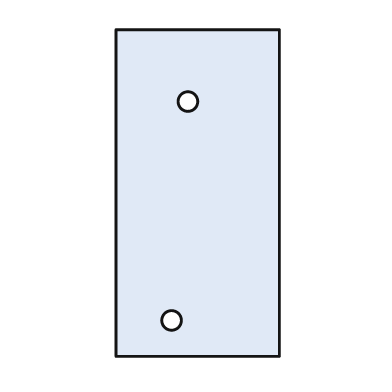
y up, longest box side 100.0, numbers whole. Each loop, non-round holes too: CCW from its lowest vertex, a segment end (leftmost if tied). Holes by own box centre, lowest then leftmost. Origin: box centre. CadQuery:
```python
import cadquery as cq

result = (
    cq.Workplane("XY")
    .moveTo(-25.0, -50.0)
    .lineTo(25.0, -50.0)
    .lineTo(25.0, 50.0)
    .lineTo(-25.0, 50.0)
    .close()
    .moveTo(-8.0, -39.0)
    .circle(3.0)
    .moveTo(-3.0, 28.0)
    .circle(3.0)
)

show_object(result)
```